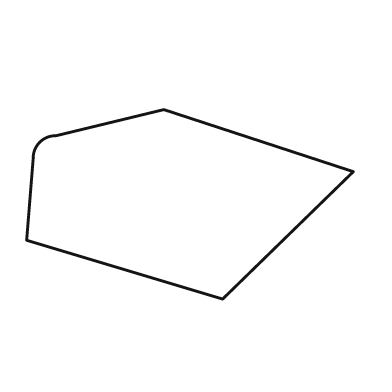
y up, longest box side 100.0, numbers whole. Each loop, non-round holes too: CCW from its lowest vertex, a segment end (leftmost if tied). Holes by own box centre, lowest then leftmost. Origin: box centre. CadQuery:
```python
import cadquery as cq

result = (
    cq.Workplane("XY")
    .moveTo(10.0, -29.0)
    .lineTo(50.0, 10.0)
    .lineTo(-8.0, 29.0)
    .lineTo(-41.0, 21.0)
    .threePointArc((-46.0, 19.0), (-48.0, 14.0))
    .lineTo(-50.0, -11.0)
    .close()
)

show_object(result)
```